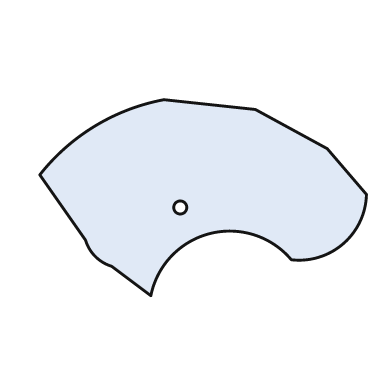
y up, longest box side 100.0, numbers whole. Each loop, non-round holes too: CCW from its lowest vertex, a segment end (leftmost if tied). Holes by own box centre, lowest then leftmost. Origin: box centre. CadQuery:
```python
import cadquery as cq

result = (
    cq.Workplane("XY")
    .moveTo(-16.0, -30.0)
    .threePointArc((2.0, -11.0), (27.0, -19.0))
    .threePointArc((43.0, -14.0), (50.0, 1.0))
    .lineTo(38.0, 15.0)
    .lineTo(16.0, 27.0)
    .lineTo(-12.0, 30.0)
    .threePointArc((-33.0, 22.0), (-50.0, 7.0))
    .lineTo(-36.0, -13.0)
    .threePointArc((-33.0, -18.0), (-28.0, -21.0))
    .close()
    .moveTo(-7.0, -3.0)
    .circle(2.0)
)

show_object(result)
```